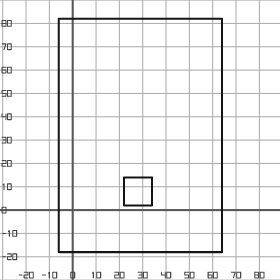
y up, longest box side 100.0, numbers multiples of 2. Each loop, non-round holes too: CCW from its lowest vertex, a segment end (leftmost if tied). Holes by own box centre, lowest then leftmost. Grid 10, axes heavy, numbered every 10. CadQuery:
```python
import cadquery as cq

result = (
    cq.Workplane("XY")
    .moveTo(-6.0, -18.0)
    .lineTo(64.0, -18.0)
    .lineTo(64.0, 82.0)
    .lineTo(-6.0, 82.0)
    .close()
    .moveTo(22.0, 2.0)
    .lineTo(34.0, 2.0)
    .lineTo(34.0, 14.0)
    .lineTo(22.0, 14.0)
    .close()
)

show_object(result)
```